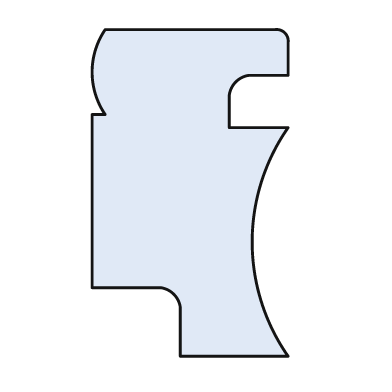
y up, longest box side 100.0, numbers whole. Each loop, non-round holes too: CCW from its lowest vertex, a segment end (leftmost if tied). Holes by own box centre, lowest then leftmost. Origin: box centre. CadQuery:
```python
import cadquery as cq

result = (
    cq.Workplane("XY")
    .moveTo(-3.0, -50.0)
    .lineTo(30.0, -50.0)
    .threePointArc((19.0, -15.0), (30.0, 20.0))
    .lineTo(12.0, 20.0)
    .lineTo(12.0, 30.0)
    .threePointArc((14.0, 34.0), (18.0, 36.0))
    .lineTo(30.0, 36.0)
    .lineTo(30.0, 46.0)
    .threePointArc((29.0, 49.0), (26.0, 50.0))
    .lineTo(-26.0, 50.0)
    .threePointArc((-30.0, 37.0), (-26.0, 24.0))
    .lineTo(-30.0, 24.0)
    .lineTo(-30.0, -29.0)
    .lineTo(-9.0, -29.0)
    .threePointArc((-5.0, -31.0), (-3.0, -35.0))
    .close()
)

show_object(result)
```